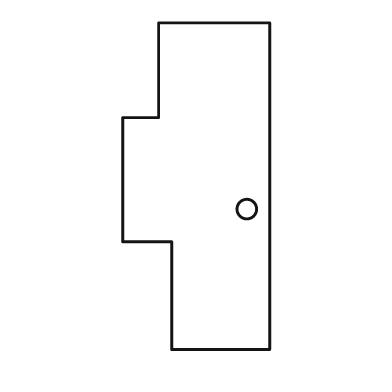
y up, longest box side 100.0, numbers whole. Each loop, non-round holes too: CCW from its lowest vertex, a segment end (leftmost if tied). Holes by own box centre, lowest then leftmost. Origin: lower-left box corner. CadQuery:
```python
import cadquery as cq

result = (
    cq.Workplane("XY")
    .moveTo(15.0, 0.0)
    .lineTo(45.0, 0.0)
    .lineTo(45.0, 100.0)
    .lineTo(11.0, 100.0)
    .lineTo(11.0, 71.0)
    .lineTo(0.0, 71.0)
    .lineTo(0.0, 33.0)
    .lineTo(15.0, 33.0)
    .close()
    .moveTo(38.0, 43.0)
    .circle(3.0)
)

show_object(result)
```